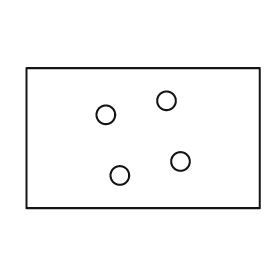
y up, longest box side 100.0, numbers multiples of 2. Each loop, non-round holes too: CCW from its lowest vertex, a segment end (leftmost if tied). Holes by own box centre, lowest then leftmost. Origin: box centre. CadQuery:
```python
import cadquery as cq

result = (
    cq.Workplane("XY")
    .moveTo(-50.0, -30.0)
    .lineTo(50.0, -30.0)
    .lineTo(50.0, 30.0)
    .lineTo(-50.0, 30.0)
    .close()
    .moveTo(-10.0, -16.0)
    .circle(4.0)
    .moveTo(16.0, -10.0)
    .circle(4.0)
    .moveTo(-16.0, 10.0)
    .circle(4.0)
    .moveTo(10.0, 16.0)
    .circle(4.0)
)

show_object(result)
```